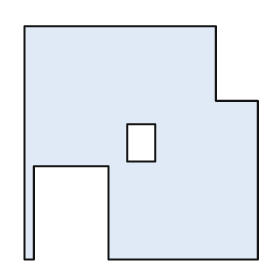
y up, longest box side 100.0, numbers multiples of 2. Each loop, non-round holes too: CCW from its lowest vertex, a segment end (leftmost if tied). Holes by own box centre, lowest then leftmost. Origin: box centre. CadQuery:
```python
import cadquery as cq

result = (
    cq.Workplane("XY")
    .moveTo(-50.0, -50.0)
    .lineTo(-46.0, -50.0)
    .lineTo(-46.0, -10.0)
    .lineTo(-14.0, -10.0)
    .lineTo(-14.0, -50.0)
    .lineTo(50.0, -50.0)
    .lineTo(50.0, 18.0)
    .lineTo(32.0, 18.0)
    .lineTo(32.0, 50.0)
    .lineTo(-50.0, 50.0)
    .close()
    .moveTo(-6.0, -8.0)
    .lineTo(6.0, -8.0)
    .lineTo(6.0, 8.0)
    .lineTo(-6.0, 8.0)
    .close()
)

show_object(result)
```